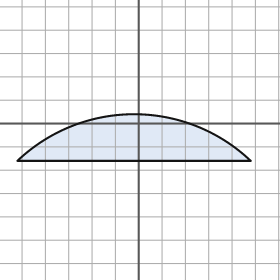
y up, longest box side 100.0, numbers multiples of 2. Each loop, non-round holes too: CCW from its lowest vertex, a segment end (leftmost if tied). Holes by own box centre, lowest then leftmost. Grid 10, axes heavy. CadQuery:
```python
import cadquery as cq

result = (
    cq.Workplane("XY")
    .moveTo(-52.0, -16.0)
    .lineTo(48.0, -16.0)
    .threePointArc((-2.0, 4.0), (-52.0, -16.0))
    .close()
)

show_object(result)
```